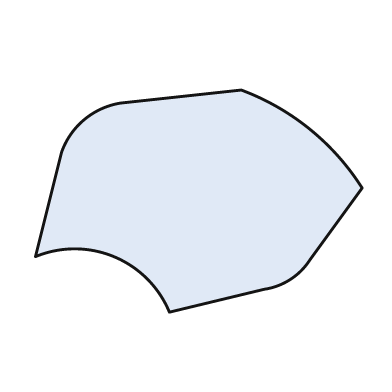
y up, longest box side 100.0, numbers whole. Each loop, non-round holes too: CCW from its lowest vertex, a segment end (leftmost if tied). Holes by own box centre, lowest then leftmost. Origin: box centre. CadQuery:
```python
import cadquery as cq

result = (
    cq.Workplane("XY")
    .moveTo(-9.0, -34.0)
    .lineTo(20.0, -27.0)
    .threePointArc((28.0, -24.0), (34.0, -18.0))
    .lineTo(50.0, 4.0)
    .threePointArc((34.0, 22.0), (13.0, 34.0))
    .lineTo(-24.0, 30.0)
    .threePointArc((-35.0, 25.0), (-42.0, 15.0))
    .lineTo(-50.0, -17.0)
    .threePointArc((-26.0, -17.0), (-9.0, -34.0))
    .close()
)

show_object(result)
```